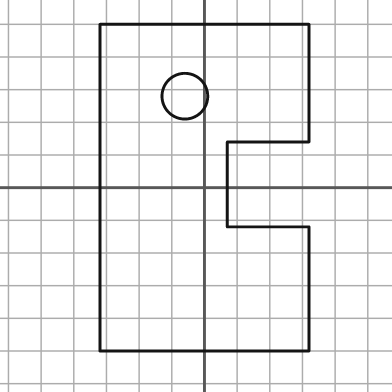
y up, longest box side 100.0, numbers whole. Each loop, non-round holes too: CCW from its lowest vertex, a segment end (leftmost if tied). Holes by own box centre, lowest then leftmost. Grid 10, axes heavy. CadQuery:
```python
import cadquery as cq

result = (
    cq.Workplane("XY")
    .moveTo(-32.0, -50.0)
    .lineTo(32.0, -50.0)
    .lineTo(32.0, -12.0)
    .lineTo(7.0, -12.0)
    .lineTo(7.0, 14.0)
    .lineTo(32.0, 14.0)
    .lineTo(32.0, 50.0)
    .lineTo(-32.0, 50.0)
    .close()
    .moveTo(-6.0, 28.0)
    .circle(7.0)
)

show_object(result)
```